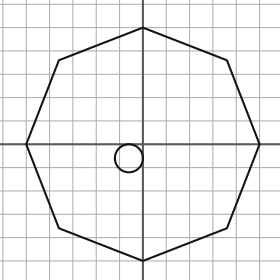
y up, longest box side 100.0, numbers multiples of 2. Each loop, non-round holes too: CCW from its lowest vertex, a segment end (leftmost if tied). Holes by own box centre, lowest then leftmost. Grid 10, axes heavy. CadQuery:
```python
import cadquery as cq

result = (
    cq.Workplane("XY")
    .moveTo(0.0, -50.0)
    .lineTo(36.0, -36.0)
    .lineTo(50.0, 0.0)
    .lineTo(36.0, 36.0)
    .lineTo(0.0, 50.0)
    .lineTo(-36.0, 36.0)
    .lineTo(-50.0, 0.0)
    .lineTo(-36.0, -36.0)
    .close()
    .moveTo(-6.0, -6.0)
    .circle(6.0)
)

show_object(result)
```